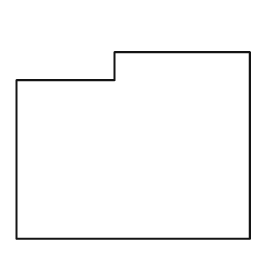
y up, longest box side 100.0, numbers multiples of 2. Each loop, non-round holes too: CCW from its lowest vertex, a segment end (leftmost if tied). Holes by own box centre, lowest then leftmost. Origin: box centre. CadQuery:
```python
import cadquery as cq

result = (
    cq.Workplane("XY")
    .moveTo(-50.0, -40.0)
    .lineTo(50.0, -40.0)
    .lineTo(50.0, 40.0)
    .lineTo(-8.0, 40.0)
    .lineTo(-8.0, 28.0)
    .lineTo(-50.0, 28.0)
    .close()
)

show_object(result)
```